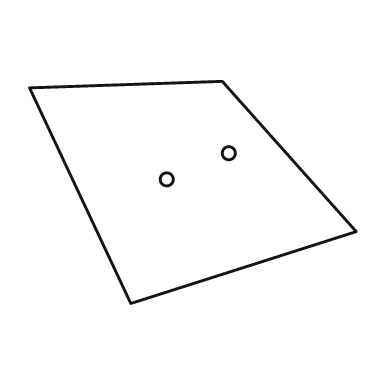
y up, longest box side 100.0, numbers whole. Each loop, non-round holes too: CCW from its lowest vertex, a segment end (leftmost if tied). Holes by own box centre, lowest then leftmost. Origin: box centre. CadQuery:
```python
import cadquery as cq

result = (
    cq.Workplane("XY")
    .moveTo(-19.0, -34.0)
    .lineTo(50.0, -12.0)
    .lineTo(9.0, 34.0)
    .lineTo(-50.0, 32.0)
    .close()
    .moveTo(-8.0, 4.0)
    .circle(2.0)
    .moveTo(11.0, 12.0)
    .circle(2.0)
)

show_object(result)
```